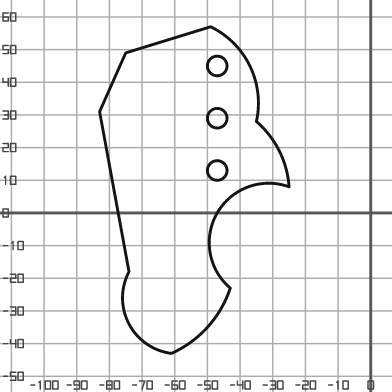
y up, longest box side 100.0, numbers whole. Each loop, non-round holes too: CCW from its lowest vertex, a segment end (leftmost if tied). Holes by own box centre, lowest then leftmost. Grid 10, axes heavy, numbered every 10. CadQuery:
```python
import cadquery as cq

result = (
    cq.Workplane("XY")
    .moveTo(-61.0, -43.0)
    .threePointArc((-50.0, -35.0), (-43.0, -23.0))
    .threePointArc((-47.0, 0.0), (-25.0, 8.0))
    .threePointArc((-28.0, 19.0), (-35.0, 28.0))
    .threePointArc((-37.0, 45.0), (-49.0, 57.0))
    .lineTo(-75.0, 49.0)
    .lineTo(-83.0, 31.0)
    .lineTo(-74.0, -18.0)
    .threePointArc((-74.0, -34.0), (-61.0, -43.0))
    .close()
    .moveTo(-47.0, 13.0)
    .circle(3.0)
    .moveTo(-47.0, 29.0)
    .circle(3.0)
    .moveTo(-47.0, 45.0)
    .circle(3.0)
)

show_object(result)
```